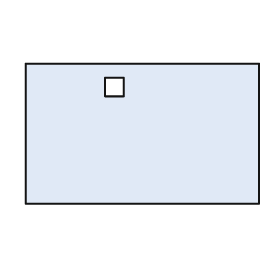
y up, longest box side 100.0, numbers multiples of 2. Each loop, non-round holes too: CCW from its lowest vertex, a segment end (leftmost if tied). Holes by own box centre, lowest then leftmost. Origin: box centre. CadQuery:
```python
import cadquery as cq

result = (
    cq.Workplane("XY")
    .moveTo(-50.0, -30.0)
    .lineTo(50.0, -30.0)
    .lineTo(50.0, 30.0)
    .lineTo(-50.0, 30.0)
    .close()
    .moveTo(-16.0, 16.0)
    .lineTo(-8.0, 16.0)
    .lineTo(-8.0, 24.0)
    .lineTo(-16.0, 24.0)
    .close()
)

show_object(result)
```